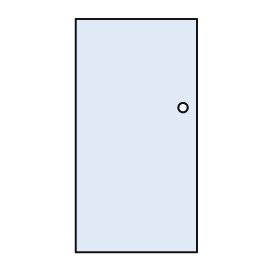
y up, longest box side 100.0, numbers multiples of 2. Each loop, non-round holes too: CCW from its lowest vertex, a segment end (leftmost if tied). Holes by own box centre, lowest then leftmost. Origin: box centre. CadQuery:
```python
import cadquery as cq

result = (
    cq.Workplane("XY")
    .moveTo(-26.0, -50.0)
    .lineTo(26.0, -50.0)
    .lineTo(26.0, 50.0)
    .lineTo(-26.0, 50.0)
    .close()
    .moveTo(20.0, 12.0)
    .circle(2.0)
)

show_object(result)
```